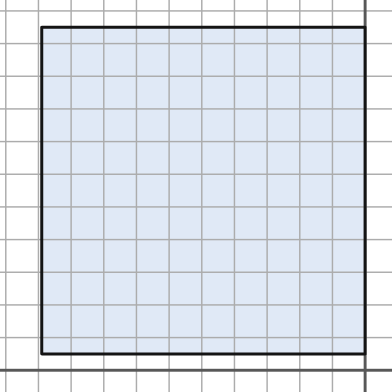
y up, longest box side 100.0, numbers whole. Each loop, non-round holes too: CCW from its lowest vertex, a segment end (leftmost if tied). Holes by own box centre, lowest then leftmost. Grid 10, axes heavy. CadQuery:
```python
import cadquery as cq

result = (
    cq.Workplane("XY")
    .moveTo(-99.0, 5.0)
    .lineTo(0.0, 5.0)
    .lineTo(0.0, 105.0)
    .lineTo(-99.0, 105.0)
    .close()
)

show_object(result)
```